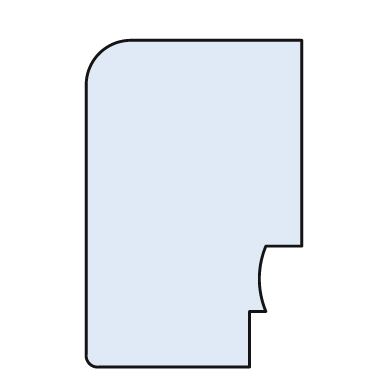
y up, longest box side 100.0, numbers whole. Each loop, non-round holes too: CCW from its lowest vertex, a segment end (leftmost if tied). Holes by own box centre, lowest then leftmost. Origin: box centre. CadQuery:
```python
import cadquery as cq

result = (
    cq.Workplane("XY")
    .moveTo(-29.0, -50.0)
    .lineTo(17.0, -50.0)
    .lineTo(17.0, -33.0)
    .lineTo(22.0, -33.0)
    .threePointArc((20.0, -23.0), (22.0, -13.0))
    .lineTo(33.0, -13.0)
    .lineTo(33.0, 50.0)
    .lineTo(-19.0, 50.0)
    .threePointArc((-29.0, 46.0), (-33.0, 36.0))
    .lineTo(-33.0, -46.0)
    .threePointArc((-32.0, -49.0), (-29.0, -50.0))
    .close()
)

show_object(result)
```